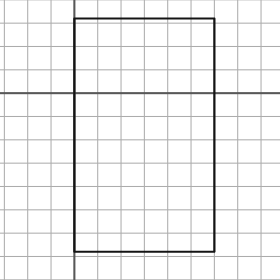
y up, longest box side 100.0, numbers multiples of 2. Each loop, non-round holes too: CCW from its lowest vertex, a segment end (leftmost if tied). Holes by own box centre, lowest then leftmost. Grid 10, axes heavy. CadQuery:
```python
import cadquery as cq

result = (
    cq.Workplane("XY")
    .moveTo(0.0, -68.0)
    .lineTo(60.0, -68.0)
    .lineTo(60.0, 32.0)
    .lineTo(0.0, 32.0)
    .close()
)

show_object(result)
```